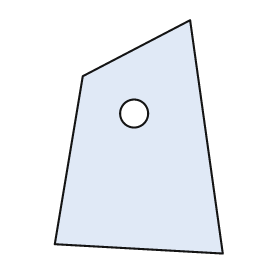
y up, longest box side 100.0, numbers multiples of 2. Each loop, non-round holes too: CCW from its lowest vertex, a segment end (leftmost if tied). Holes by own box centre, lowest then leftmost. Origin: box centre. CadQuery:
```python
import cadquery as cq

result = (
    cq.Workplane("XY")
    .moveTo(36.0, -50.0)
    .lineTo(22.0, 50.0)
    .lineTo(-24.0, 26.0)
    .lineTo(-36.0, -46.0)
    .close()
    .moveTo(-2.0, 10.0)
    .circle(6.0)
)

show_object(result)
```